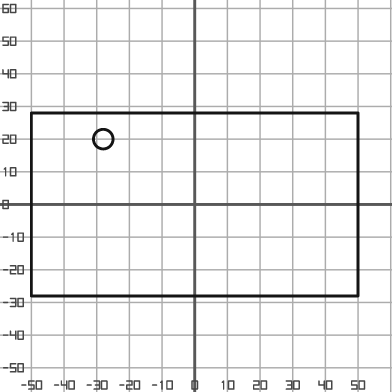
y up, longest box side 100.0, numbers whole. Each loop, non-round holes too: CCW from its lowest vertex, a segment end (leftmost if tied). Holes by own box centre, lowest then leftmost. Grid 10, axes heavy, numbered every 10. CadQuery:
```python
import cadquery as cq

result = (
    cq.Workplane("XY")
    .moveTo(-50.0, -28.0)
    .lineTo(50.0, -28.0)
    .lineTo(50.0, 28.0)
    .lineTo(-50.0, 28.0)
    .close()
    .moveTo(-28.0, 20.0)
    .circle(3.0)
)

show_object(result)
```